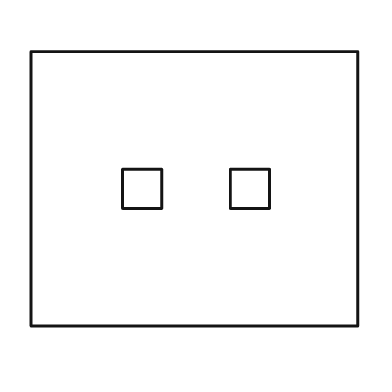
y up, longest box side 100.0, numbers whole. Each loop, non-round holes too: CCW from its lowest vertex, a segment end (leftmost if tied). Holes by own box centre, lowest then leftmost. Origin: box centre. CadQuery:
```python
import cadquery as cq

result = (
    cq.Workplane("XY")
    .moveTo(-50.0, -42.0)
    .lineTo(50.0, -42.0)
    .lineTo(50.0, 42.0)
    .lineTo(-50.0, 42.0)
    .close()
    .moveTo(-22.0, -6.0)
    .lineTo(-10.0, -6.0)
    .lineTo(-10.0, 6.0)
    .lineTo(-22.0, 6.0)
    .close()
    .moveTo(11.0, -6.0)
    .lineTo(23.0, -6.0)
    .lineTo(23.0, 6.0)
    .lineTo(11.0, 6.0)
    .close()
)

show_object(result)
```